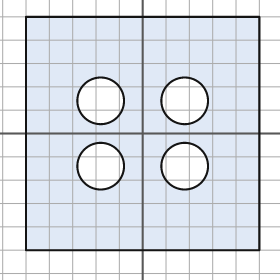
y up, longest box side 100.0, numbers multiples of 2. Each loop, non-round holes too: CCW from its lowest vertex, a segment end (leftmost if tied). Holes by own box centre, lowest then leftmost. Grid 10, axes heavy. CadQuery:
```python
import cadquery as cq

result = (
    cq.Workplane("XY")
    .moveTo(-50.0, -50.0)
    .lineTo(50.0, -50.0)
    .lineTo(50.0, 50.0)
    .lineTo(-50.0, 50.0)
    .close()
    .moveTo(-18.0, -14.0)
    .circle(10.0)
    .moveTo(18.0, -14.0)
    .circle(10.0)
    .moveTo(-18.0, 14.0)
    .circle(10.0)
    .moveTo(18.0, 14.0)
    .circle(10.0)
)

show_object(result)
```